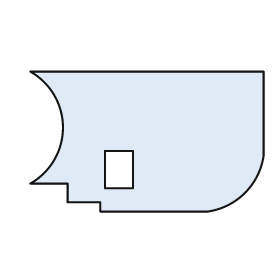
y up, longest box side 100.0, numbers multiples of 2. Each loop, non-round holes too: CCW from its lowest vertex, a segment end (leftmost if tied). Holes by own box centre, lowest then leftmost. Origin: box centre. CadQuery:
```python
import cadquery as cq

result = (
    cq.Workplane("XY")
    .moveTo(-20.0, -30.0)
    .lineTo(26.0, -30.0)
    .threePointArc((42.0, -22.0), (50.0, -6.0))
    .lineTo(50.0, 30.0)
    .lineTo(-50.0, 30.0)
    .threePointArc((-36.0, 6.0), (-50.0, -18.0))
    .lineTo(-34.0, -18.0)
    .lineTo(-34.0, -26.0)
    .lineTo(-20.0, -26.0)
    .close()
    .moveTo(-18.0, -20.0)
    .lineTo(-6.0, -20.0)
    .lineTo(-6.0, -4.0)
    .lineTo(-18.0, -4.0)
    .close()
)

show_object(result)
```